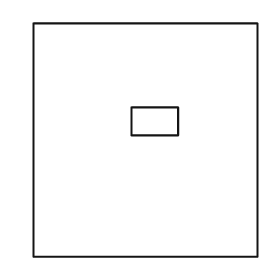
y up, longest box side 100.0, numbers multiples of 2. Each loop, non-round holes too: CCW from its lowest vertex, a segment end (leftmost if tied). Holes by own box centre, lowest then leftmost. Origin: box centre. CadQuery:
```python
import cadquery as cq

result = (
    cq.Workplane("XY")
    .moveTo(-48.0, -50.0)
    .lineTo(48.0, -50.0)
    .lineTo(48.0, 50.0)
    .lineTo(-48.0, 50.0)
    .close()
    .moveTo(-6.0, 2.0)
    .lineTo(14.0, 2.0)
    .lineTo(14.0, 14.0)
    .lineTo(-6.0, 14.0)
    .close()
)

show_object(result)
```